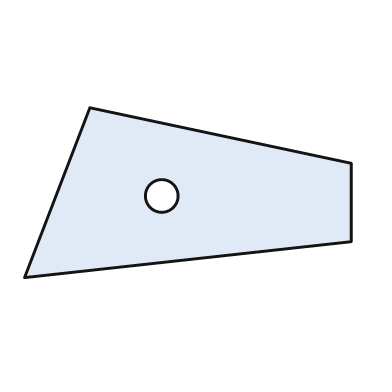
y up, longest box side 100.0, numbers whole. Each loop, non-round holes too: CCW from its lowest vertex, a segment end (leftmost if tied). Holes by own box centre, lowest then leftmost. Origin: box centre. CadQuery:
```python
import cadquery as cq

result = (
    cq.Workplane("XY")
    .moveTo(-50.0, -26.0)
    .lineTo(50.0, -15.0)
    .lineTo(50.0, 9.0)
    .lineTo(-30.0, 26.0)
    .close()
    .moveTo(-8.0, -1.0)
    .circle(5.0)
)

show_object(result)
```